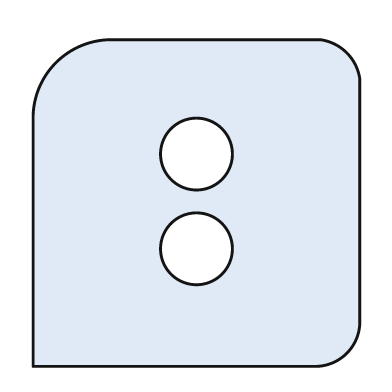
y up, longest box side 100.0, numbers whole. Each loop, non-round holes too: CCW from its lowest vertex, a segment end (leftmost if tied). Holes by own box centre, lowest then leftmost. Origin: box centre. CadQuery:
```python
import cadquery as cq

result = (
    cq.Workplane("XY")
    .moveTo(-50.0, -50.0)
    .lineTo(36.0, -50.0)
    .threePointArc((46.0, -46.0), (50.0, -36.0))
    .lineTo(50.0, 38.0)
    .threePointArc((46.0, 46.0), (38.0, 50.0))
    .lineTo(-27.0, 50.0)
    .threePointArc((-43.0, 43.0), (-50.0, 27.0))
    .close()
    .moveTo(0.0, -14.0)
    .circle(11.0)
    .moveTo(0.0, 15.0)
    .circle(11.0)
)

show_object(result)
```